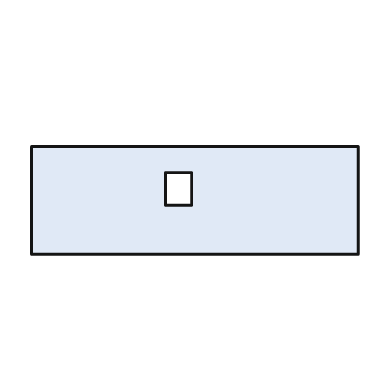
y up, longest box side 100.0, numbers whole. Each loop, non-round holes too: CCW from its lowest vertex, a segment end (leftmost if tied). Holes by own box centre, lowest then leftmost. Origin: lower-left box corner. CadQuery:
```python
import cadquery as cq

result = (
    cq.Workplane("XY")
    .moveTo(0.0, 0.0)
    .lineTo(100.0, 0.0)
    .lineTo(100.0, 33.0)
    .lineTo(0.0, 33.0)
    .close()
    .moveTo(41.0, 15.0)
    .lineTo(49.0, 15.0)
    .lineTo(49.0, 25.0)
    .lineTo(41.0, 25.0)
    .close()
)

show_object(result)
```